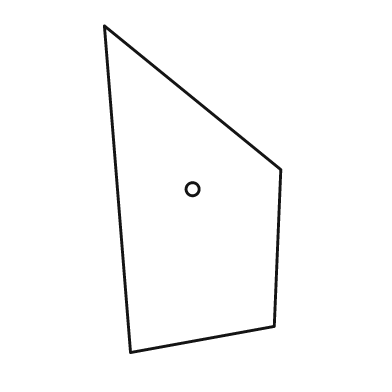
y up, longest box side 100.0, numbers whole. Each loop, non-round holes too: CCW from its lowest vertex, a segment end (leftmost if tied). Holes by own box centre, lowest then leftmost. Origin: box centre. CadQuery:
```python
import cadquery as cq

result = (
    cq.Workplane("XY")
    .moveTo(-19.0, -50.0)
    .lineTo(25.0, -42.0)
    .lineTo(27.0, 6.0)
    .lineTo(-27.0, 50.0)
    .close()
    .moveTo(0.0, 0.0)
    .circle(2.0)
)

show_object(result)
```